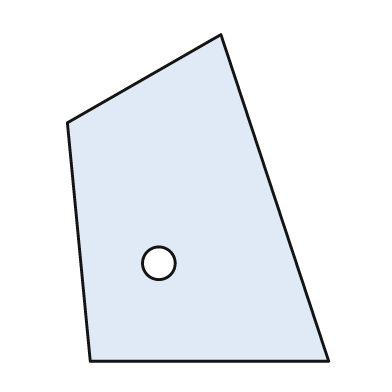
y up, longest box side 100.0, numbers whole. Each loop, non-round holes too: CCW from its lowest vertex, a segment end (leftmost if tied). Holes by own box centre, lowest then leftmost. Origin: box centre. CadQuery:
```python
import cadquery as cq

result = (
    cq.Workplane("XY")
    .moveTo(-33.0, -50.0)
    .lineTo(40.0, -50.0)
    .lineTo(7.0, 50.0)
    .lineTo(-40.0, 23.0)
    .close()
    .moveTo(-12.0, -20.0)
    .circle(5.0)
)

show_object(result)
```